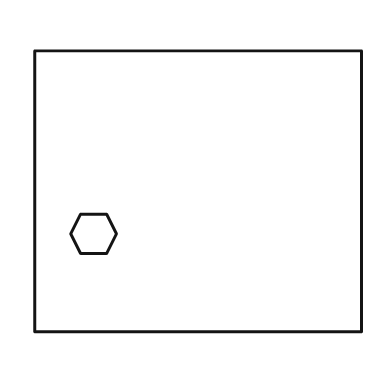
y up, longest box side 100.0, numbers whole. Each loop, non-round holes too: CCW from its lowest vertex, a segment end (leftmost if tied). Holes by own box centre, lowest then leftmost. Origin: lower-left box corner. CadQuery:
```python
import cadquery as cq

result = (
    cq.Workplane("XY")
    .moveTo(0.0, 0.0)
    .lineTo(100.0, 0.0)
    .lineTo(100.0, 86.0)
    .lineTo(0.0, 86.0)
    .close()
    .moveTo(14.0, 24.0)
    .lineTo(22.0, 24.0)
    .lineTo(25.0, 30.0)
    .lineTo(22.0, 36.0)
    .lineTo(14.0, 36.0)
    .lineTo(11.0, 30.0)
    .close()
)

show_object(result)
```